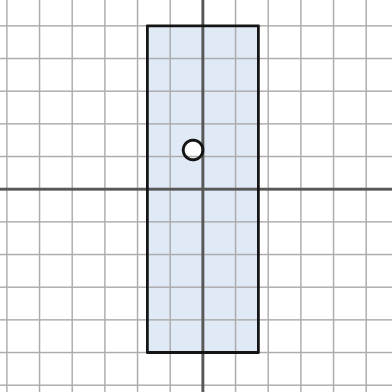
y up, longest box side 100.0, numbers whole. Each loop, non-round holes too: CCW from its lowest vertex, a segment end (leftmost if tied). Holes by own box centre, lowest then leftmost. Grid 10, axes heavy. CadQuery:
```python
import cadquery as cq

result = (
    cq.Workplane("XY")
    .moveTo(-17.0, -50.0)
    .lineTo(17.0, -50.0)
    .lineTo(17.0, 50.0)
    .lineTo(-17.0, 50.0)
    .close()
    .moveTo(-3.0, 12.0)
    .circle(3.0)
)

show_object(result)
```